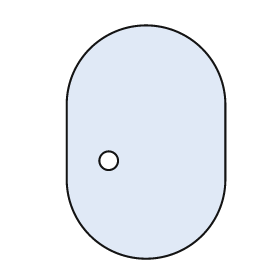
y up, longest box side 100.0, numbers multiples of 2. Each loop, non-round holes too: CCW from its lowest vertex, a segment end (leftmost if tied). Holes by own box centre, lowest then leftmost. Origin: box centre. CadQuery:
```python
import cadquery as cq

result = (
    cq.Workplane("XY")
    .moveTo(-34.0, -16.0)
    .threePointArc((0.0, -50.0), (34.0, -16.0))
    .lineTo(34.0, 16.0)
    .threePointArc((0.0, 50.0), (-34.0, 16.0))
    .close()
    .moveTo(-16.0, -8.0)
    .circle(4.0)
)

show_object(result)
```